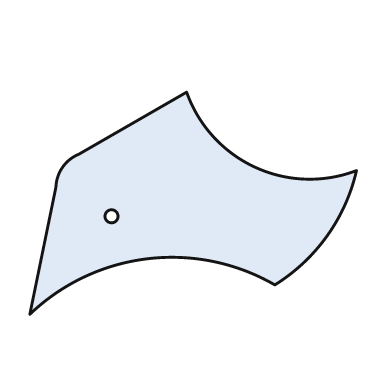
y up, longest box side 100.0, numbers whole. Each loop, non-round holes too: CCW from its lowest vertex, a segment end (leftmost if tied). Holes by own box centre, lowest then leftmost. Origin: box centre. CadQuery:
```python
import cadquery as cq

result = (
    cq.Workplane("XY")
    .moveTo(-50.0, -34.0)
    .threePointArc((-14.0, -17.0), (25.0, -25.0))
    .threePointArc((41.0, -10.0), (50.0, 10.0))
    .threePointArc((19.0, 11.0), (-2.0, 34.0))
    .lineTo(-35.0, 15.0)
    .threePointArc((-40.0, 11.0), (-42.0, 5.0))
    .close()
    .moveTo(-25.0, -4.0)
    .circle(2.0)
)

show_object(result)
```